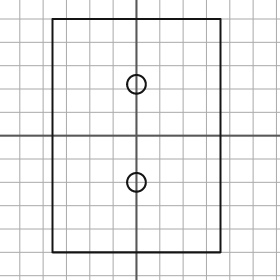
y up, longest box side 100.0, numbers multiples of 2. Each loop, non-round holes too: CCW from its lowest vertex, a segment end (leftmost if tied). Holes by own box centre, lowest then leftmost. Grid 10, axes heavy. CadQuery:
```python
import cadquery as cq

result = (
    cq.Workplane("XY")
    .moveTo(-36.0, -50.0)
    .lineTo(36.0, -50.0)
    .lineTo(36.0, 50.0)
    .lineTo(-36.0, 50.0)
    .close()
    .moveTo(0.0, -20.0)
    .circle(4.0)
    .moveTo(0.0, 22.0)
    .circle(4.0)
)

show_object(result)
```